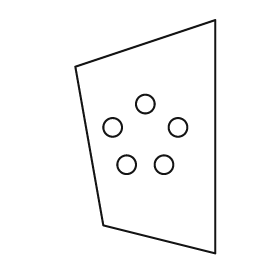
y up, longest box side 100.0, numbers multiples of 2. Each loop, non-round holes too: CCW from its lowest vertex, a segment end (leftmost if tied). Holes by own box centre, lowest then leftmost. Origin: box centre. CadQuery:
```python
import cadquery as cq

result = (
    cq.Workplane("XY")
    .moveTo(30.0, -50.0)
    .lineTo(30.0, 50.0)
    .lineTo(-30.0, 30.0)
    .lineTo(-18.0, -38.0)
    .close()
    .moveTo(-8.0, -12.0)
    .circle(4.0)
    .moveTo(8.0, -12.0)
    .circle(4.0)
    .moveTo(-14.0, 4.0)
    .circle(4.0)
    .moveTo(14.0, 4.0)
    .circle(4.0)
    .moveTo(0.0, 14.0)
    .circle(4.0)
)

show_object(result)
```